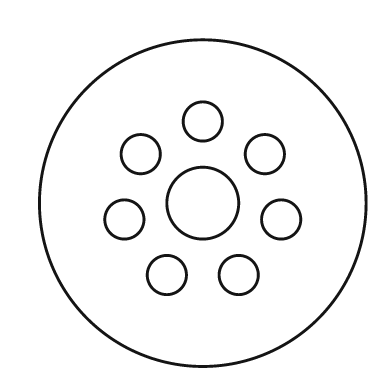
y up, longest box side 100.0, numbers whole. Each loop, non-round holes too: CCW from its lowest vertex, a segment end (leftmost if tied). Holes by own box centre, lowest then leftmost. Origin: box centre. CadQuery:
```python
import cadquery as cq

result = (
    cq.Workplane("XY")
    .moveTo(0.0, 0.0)
    .circle(50.0)
    .moveTo(-11.0, -22.0)
    .circle(6.0)
    .moveTo(11.0, -22.0)
    .circle(6.0)
    .moveTo(-24.0, -5.0)
    .circle(6.0)
    .moveTo(24.0, -5.0)
    .circle(6.0)
    .moveTo(0.0, 0.0)
    .circle(11.0)
    .moveTo(-19.0, 15.0)
    .circle(6.0)
    .moveTo(19.0, 15.0)
    .circle(6.0)
    .moveTo(0.0, 25.0)
    .circle(6.0)
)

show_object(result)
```